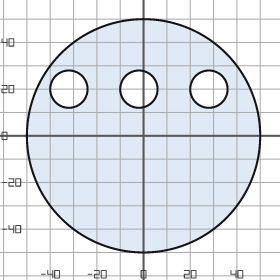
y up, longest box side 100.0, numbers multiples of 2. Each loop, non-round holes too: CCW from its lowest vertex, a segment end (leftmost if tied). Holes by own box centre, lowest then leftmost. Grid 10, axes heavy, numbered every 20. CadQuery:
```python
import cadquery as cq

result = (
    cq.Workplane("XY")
    .moveTo(0.0, 0.0)
    .circle(50.0)
    .moveTo(-32.0, 20.0)
    .circle(8.0)
    .moveTo(-2.0, 20.0)
    .circle(8.0)
    .moveTo(28.0, 20.0)
    .circle(8.0)
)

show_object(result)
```